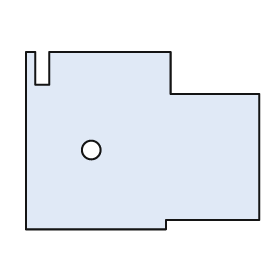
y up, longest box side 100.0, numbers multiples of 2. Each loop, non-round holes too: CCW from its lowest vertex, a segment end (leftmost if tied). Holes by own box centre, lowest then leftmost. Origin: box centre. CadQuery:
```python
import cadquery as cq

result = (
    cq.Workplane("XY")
    .moveTo(-50.0, -38.0)
    .lineTo(10.0, -38.0)
    .lineTo(10.0, -34.0)
    .lineTo(50.0, -34.0)
    .lineTo(50.0, 20.0)
    .lineTo(12.0, 20.0)
    .lineTo(12.0, 38.0)
    .lineTo(-40.0, 38.0)
    .lineTo(-40.0, 24.0)
    .lineTo(-46.0, 24.0)
    .lineTo(-46.0, 38.0)
    .lineTo(-50.0, 38.0)
    .close()
    .moveTo(-22.0, -4.0)
    .circle(4.0)
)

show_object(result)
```